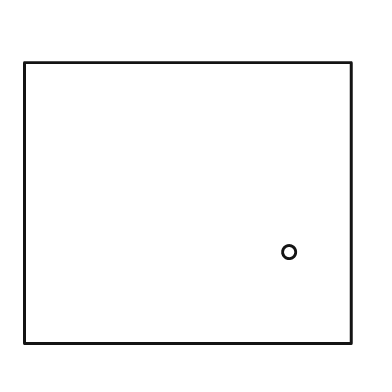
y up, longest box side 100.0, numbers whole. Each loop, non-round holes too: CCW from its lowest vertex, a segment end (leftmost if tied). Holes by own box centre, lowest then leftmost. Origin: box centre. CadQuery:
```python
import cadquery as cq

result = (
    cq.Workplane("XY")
    .moveTo(-50.0, -43.0)
    .lineTo(50.0, -43.0)
    .lineTo(50.0, 43.0)
    .lineTo(-50.0, 43.0)
    .close()
    .moveTo(31.0, -15.0)
    .circle(2.0)
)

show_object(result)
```